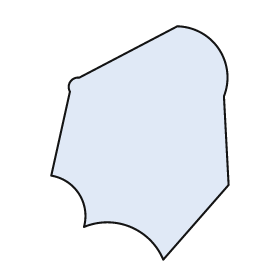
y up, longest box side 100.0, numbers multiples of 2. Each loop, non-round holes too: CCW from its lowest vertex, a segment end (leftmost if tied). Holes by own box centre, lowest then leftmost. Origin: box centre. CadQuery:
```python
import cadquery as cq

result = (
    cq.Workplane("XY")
    .moveTo(10.0, -50.0)
    .lineTo(38.0, -18.0)
    .lineTo(36.0, 20.0)
    .threePointArc((34.0, 40.0), (16.0, 50.0))
    .lineTo(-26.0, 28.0)
    .threePointArc((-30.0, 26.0), (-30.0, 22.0))
    .lineTo(-38.0, -14.0)
    .threePointArc((-26.0, -22.0), (-24.0, -36.0))
    .threePointArc((-4.0, -36.0), (10.0, -50.0))
    .close()
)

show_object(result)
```